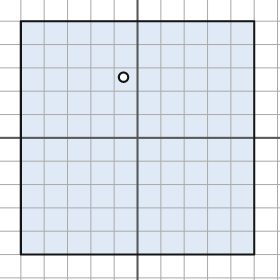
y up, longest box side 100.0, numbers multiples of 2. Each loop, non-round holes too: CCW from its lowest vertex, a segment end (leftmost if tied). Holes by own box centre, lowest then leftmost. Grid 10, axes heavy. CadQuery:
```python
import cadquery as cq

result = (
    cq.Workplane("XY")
    .moveTo(-50.0, -50.0)
    .lineTo(50.0, -50.0)
    .lineTo(50.0, 50.0)
    .lineTo(-50.0, 50.0)
    .close()
    .moveTo(-6.0, 26.0)
    .circle(2.0)
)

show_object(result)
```